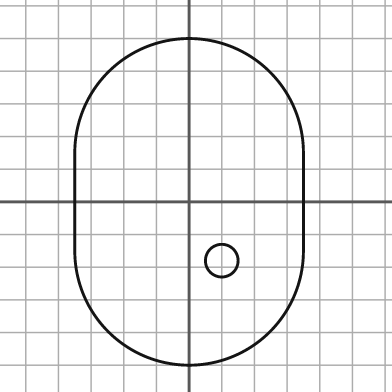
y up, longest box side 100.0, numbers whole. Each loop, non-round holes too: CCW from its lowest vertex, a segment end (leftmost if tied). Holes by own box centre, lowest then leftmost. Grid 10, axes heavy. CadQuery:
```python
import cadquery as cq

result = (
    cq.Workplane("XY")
    .moveTo(-35.0, -15.0)
    .threePointArc((0.0, -50.0), (35.0, -15.0))
    .lineTo(35.0, 15.0)
    .threePointArc((0.0, 50.0), (-35.0, 15.0))
    .close()
    .moveTo(10.0, -18.0)
    .circle(5.0)
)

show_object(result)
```